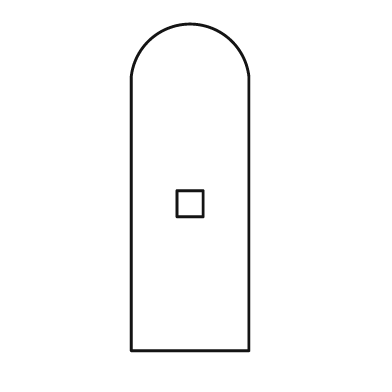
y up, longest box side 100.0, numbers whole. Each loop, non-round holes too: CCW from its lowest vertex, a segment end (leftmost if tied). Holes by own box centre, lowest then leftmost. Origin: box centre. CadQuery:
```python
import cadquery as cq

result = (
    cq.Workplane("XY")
    .moveTo(-18.0, -50.0)
    .lineTo(18.0, -50.0)
    .lineTo(18.0, 34.0)
    .threePointArc((0.0, 50.0), (-18.0, 34.0))
    .close()
    .moveTo(-4.0, -9.0)
    .lineTo(4.0, -9.0)
    .lineTo(4.0, -1.0)
    .lineTo(-4.0, -1.0)
    .close()
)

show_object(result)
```